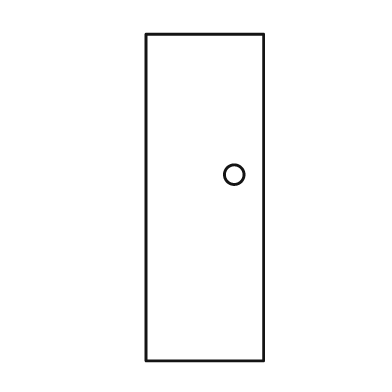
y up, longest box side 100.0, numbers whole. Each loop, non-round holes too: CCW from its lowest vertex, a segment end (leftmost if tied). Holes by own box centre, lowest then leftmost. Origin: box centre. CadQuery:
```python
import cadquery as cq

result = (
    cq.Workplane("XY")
    .moveTo(-18.0, -50.0)
    .lineTo(18.0, -50.0)
    .lineTo(18.0, 50.0)
    .lineTo(-18.0, 50.0)
    .close()
    .moveTo(9.0, 7.0)
    .circle(3.0)
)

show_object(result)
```